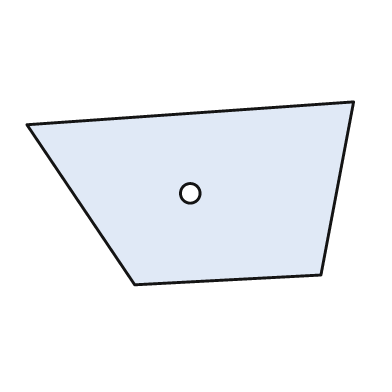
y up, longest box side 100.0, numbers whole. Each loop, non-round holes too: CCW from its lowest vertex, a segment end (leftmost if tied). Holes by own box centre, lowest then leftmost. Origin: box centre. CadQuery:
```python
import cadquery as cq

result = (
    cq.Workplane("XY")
    .moveTo(-17.0, -28.0)
    .lineTo(40.0, -25.0)
    .lineTo(50.0, 28.0)
    .lineTo(-50.0, 21.0)
    .close()
    .moveTo(0.0, 0.0)
    .circle(3.0)
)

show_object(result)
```